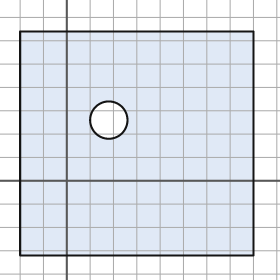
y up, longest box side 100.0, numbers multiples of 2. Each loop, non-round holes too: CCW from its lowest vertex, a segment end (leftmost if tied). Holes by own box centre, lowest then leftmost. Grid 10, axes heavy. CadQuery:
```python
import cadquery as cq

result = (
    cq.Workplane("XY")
    .moveTo(-20.0, -32.0)
    .lineTo(80.0, -32.0)
    .lineTo(80.0, 64.0)
    .lineTo(-20.0, 64.0)
    .close()
    .moveTo(18.0, 26.0)
    .circle(8.0)
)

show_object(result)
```